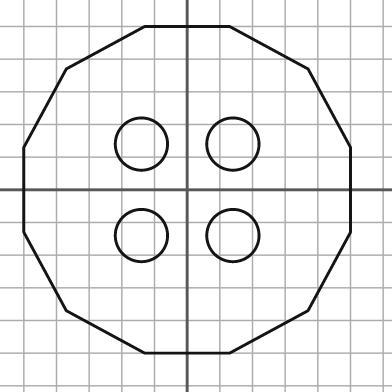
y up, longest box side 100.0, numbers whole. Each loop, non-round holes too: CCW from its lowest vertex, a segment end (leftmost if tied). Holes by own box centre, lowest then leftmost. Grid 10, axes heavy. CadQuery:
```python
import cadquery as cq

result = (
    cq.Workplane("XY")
    .moveTo(-13.0, -50.0)
    .lineTo(13.0, -50.0)
    .lineTo(37.0, -37.0)
    .lineTo(50.0, -13.0)
    .lineTo(50.0, 13.0)
    .lineTo(37.0, 37.0)
    .lineTo(13.0, 50.0)
    .lineTo(-13.0, 50.0)
    .lineTo(-37.0, 37.0)
    .lineTo(-50.0, 13.0)
    .lineTo(-50.0, -13.0)
    .lineTo(-37.0, -37.0)
    .close()
    .moveTo(-14.0, -14.0)
    .circle(8.0)
    .moveTo(14.0, -14.0)
    .circle(8.0)
    .moveTo(-14.0, 14.0)
    .circle(8.0)
    .moveTo(14.0, 14.0)
    .circle(8.0)
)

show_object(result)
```